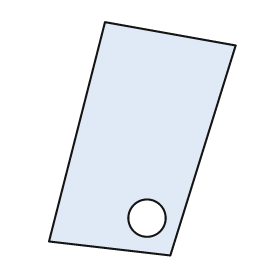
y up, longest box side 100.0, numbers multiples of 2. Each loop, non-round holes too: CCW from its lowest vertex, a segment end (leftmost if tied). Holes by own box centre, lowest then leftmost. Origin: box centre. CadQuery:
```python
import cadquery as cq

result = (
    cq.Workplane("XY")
    .moveTo(12.0, -50.0)
    .lineTo(40.0, 40.0)
    .lineTo(-16.0, 50.0)
    .lineTo(-40.0, -44.0)
    .close()
    .moveTo(2.0, -34.0)
    .circle(8.0)
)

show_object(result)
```